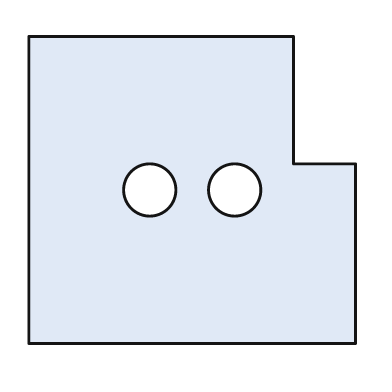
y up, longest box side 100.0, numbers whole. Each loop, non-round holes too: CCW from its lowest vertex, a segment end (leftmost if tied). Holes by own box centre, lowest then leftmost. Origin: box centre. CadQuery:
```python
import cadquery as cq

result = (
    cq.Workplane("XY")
    .moveTo(-50.0, -47.0)
    .lineTo(50.0, -47.0)
    .lineTo(50.0, 8.0)
    .lineTo(31.0, 8.0)
    .lineTo(31.0, 47.0)
    .lineTo(-50.0, 47.0)
    .close()
    .moveTo(-13.0, 0.0)
    .circle(8.0)
    .moveTo(13.0, 0.0)
    .circle(8.0)
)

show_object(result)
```